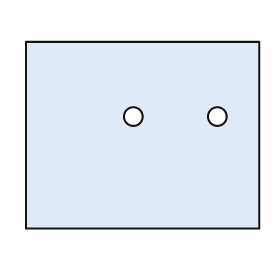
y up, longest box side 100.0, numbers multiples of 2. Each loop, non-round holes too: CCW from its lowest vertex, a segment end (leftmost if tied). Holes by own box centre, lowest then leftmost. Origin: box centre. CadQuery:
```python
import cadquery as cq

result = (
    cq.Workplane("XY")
    .moveTo(-50.0, -40.0)
    .lineTo(50.0, -40.0)
    .lineTo(50.0, 40.0)
    .lineTo(-50.0, 40.0)
    .close()
    .moveTo(-4.0, 8.0)
    .circle(4.0)
    .moveTo(32.0, 8.0)
    .circle(4.0)
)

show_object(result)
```